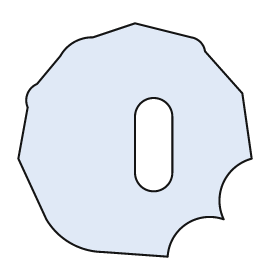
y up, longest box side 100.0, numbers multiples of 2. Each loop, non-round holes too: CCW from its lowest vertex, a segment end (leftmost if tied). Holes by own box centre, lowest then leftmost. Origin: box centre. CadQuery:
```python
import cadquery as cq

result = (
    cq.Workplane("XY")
    .moveTo(14.0, -50.0)
    .threePointArc((22.0, -36.0), (38.0, -34.0))
    .threePointArc((38.0, -18.0), (50.0, -8.0))
    .lineTo(46.0, 20.0)
    .lineTo(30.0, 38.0)
    .threePointArc((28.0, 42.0), (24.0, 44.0))
    .lineTo(0.0, 50.0)
    .lineTo(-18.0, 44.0)
    .threePointArc((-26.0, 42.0), (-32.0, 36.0))
    .lineTo(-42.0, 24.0)
    .threePointArc((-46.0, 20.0), (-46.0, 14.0))
    .lineTo(-50.0, -8.0)
    .lineTo(-38.0, -34.0)
    .threePointArc((-28.0, -44.0), (-14.0, -48.0))
    .close()
    .moveTo(0.0, -14.0)
    .threePointArc((8.0, -22.0), (16.0, -14.0))
    .lineTo(16.0, 10.0)
    .threePointArc((8.0, 18.0), (0.0, 10.0))
    .close()
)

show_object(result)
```